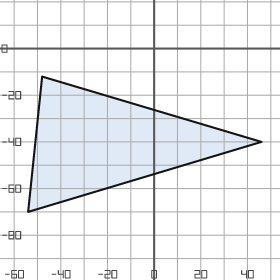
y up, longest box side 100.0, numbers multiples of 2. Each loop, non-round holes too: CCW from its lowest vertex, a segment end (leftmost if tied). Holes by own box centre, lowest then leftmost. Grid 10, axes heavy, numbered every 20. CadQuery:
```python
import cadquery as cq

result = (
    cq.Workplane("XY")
    .moveTo(-54.0, -70.0)
    .lineTo(46.0, -40.0)
    .lineTo(-48.0, -12.0)
    .close()
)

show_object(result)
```